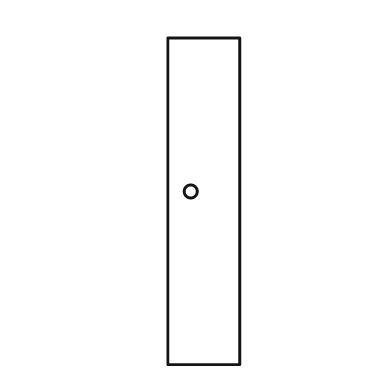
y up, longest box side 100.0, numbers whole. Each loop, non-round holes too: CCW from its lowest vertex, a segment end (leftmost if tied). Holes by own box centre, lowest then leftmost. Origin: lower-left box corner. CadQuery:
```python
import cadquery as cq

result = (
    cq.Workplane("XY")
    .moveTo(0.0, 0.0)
    .lineTo(22.0, 0.0)
    .lineTo(22.0, 100.0)
    .lineTo(0.0, 100.0)
    .close()
    .moveTo(7.0, 53.0)
    .circle(2.0)
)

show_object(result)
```